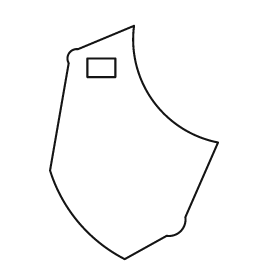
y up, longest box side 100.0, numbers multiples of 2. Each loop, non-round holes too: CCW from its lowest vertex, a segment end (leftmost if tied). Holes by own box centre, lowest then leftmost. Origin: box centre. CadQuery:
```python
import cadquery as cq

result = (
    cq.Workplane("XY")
    .moveTo(-4.0, -50.0)
    .lineTo(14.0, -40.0)
    .threePointArc((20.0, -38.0), (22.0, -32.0))
    .lineTo(36.0, 0.0)
    .threePointArc((8.0, 18.0), (0.0, 50.0))
    .lineTo(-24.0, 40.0)
    .threePointArc((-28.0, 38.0), (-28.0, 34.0))
    .lineTo(-36.0, -12.0)
    .threePointArc((-24.0, -34.0), (-4.0, -50.0))
    .close()
    .moveTo(-20.0, 28.0)
    .lineTo(-8.0, 28.0)
    .lineTo(-8.0, 36.0)
    .lineTo(-20.0, 36.0)
    .close()
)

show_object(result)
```